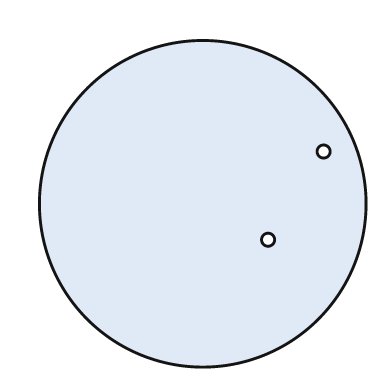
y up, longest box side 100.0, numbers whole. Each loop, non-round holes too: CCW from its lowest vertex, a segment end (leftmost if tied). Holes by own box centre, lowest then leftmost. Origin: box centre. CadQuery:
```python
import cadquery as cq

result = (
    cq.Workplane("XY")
    .moveTo(0.0, 0.0)
    .circle(50.0)
    .moveTo(20.0, -11.0)
    .circle(2.0)
    .moveTo(37.0, 16.0)
    .circle(2.0)
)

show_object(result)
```